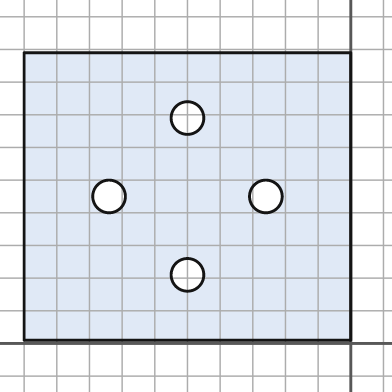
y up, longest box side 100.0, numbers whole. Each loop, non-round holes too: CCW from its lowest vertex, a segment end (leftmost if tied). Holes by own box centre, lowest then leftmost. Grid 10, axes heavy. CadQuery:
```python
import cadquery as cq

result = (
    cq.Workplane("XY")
    .moveTo(-100.0, 1.0)
    .lineTo(0.0, 1.0)
    .lineTo(0.0, 89.0)
    .lineTo(-100.0, 89.0)
    .close()
    .moveTo(-50.0, 21.0)
    .circle(5.0)
    .moveTo(-74.0, 45.0)
    .circle(5.0)
    .moveTo(-26.0, 45.0)
    .circle(5.0)
    .moveTo(-50.0, 69.0)
    .circle(5.0)
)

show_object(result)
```